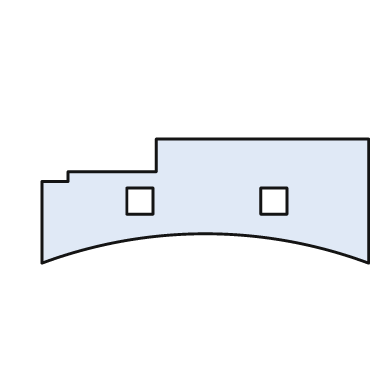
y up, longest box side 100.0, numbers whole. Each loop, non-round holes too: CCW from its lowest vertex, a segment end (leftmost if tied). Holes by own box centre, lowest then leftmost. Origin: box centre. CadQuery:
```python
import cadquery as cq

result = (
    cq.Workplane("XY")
    .moveTo(-50.0, -19.0)
    .threePointArc((0.0, -10.0), (50.0, -19.0))
    .lineTo(50.0, 19.0)
    .lineTo(-15.0, 19.0)
    .lineTo(-15.0, 9.0)
    .lineTo(-42.0, 9.0)
    .lineTo(-42.0, 6.0)
    .lineTo(-50.0, 6.0)
    .close()
    .moveTo(-24.0, -4.0)
    .lineTo(-16.0, -4.0)
    .lineTo(-16.0, 4.0)
    .lineTo(-24.0, 4.0)
    .close()
    .moveTo(17.0, -4.0)
    .lineTo(25.0, -4.0)
    .lineTo(25.0, 4.0)
    .lineTo(17.0, 4.0)
    .close()
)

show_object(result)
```